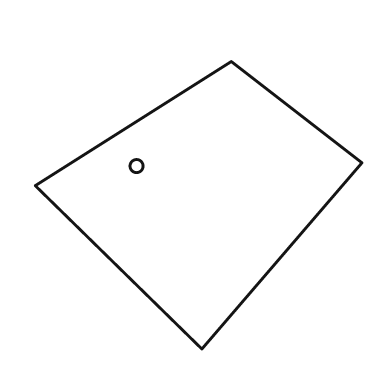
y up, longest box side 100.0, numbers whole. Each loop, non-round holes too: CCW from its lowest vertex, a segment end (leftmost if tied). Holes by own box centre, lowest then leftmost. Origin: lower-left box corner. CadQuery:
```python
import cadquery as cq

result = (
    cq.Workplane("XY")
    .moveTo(51.0, 0.0)
    .lineTo(100.0, 57.0)
    .lineTo(60.0, 88.0)
    .lineTo(0.0, 50.0)
    .close()
    .moveTo(31.0, 56.0)
    .circle(2.0)
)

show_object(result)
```